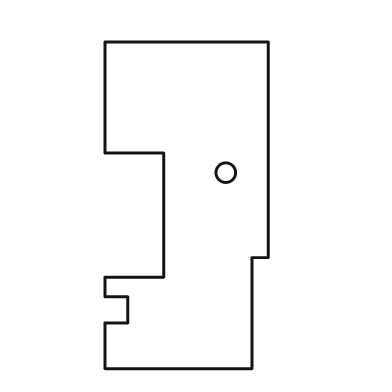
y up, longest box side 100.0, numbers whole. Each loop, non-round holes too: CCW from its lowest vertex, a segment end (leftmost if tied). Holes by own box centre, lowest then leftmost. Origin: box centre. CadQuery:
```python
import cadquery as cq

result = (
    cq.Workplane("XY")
    .moveTo(-25.0, -50.0)
    .lineTo(20.0, -50.0)
    .lineTo(20.0, -16.0)
    .lineTo(25.0, -16.0)
    .lineTo(25.0, 50.0)
    .lineTo(-25.0, 50.0)
    .lineTo(-25.0, 16.0)
    .lineTo(-7.0, 16.0)
    .lineTo(-7.0, -22.0)
    .lineTo(-25.0, -22.0)
    .lineTo(-25.0, -28.0)
    .lineTo(-18.0, -28.0)
    .lineTo(-18.0, -36.0)
    .lineTo(-25.0, -36.0)
    .close()
    .moveTo(12.0, 10.0)
    .circle(3.0)
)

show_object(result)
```